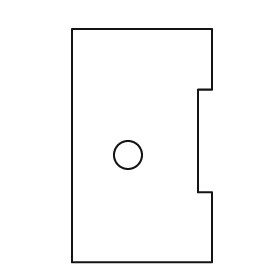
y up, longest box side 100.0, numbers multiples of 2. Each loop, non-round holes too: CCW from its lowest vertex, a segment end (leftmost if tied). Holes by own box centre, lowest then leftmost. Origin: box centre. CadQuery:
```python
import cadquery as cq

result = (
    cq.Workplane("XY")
    .moveTo(-30.0, -50.0)
    .lineTo(30.0, -50.0)
    .lineTo(30.0, -20.0)
    .lineTo(24.0, -20.0)
    .lineTo(24.0, 24.0)
    .lineTo(30.0, 24.0)
    .lineTo(30.0, 50.0)
    .lineTo(-30.0, 50.0)
    .close()
    .moveTo(-6.0, -4.0)
    .circle(6.0)
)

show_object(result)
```